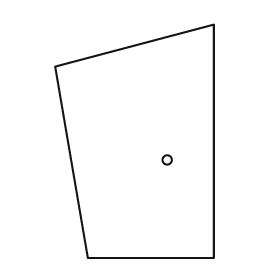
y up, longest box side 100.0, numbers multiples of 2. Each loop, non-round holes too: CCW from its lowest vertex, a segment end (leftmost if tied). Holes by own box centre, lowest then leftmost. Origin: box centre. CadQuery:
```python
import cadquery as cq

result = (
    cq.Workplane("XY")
    .moveTo(-20.0, -50.0)
    .lineTo(34.0, -50.0)
    .lineTo(34.0, 50.0)
    .lineTo(-34.0, 32.0)
    .close()
    .moveTo(14.0, -8.0)
    .circle(2.0)
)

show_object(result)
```